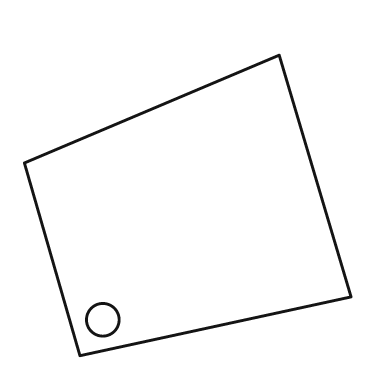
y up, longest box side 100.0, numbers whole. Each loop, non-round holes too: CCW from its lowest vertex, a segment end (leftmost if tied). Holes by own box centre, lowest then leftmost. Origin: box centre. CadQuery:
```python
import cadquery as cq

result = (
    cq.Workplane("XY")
    .moveTo(-33.0, -46.0)
    .lineTo(50.0, -28.0)
    .lineTo(28.0, 46.0)
    .lineTo(-50.0, 13.0)
    .close()
    .moveTo(-26.0, -35.0)
    .circle(5.0)
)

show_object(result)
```